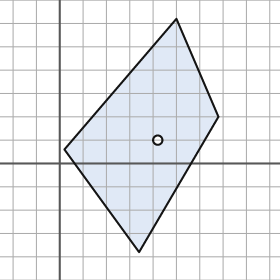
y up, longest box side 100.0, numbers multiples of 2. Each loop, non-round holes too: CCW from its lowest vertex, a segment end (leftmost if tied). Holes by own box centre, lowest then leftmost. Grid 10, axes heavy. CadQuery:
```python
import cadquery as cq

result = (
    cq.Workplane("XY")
    .moveTo(34.0, -38.0)
    .lineTo(68.0, 20.0)
    .lineTo(50.0, 62.0)
    .lineTo(2.0, 6.0)
    .close()
    .moveTo(42.0, 10.0)
    .circle(2.0)
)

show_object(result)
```